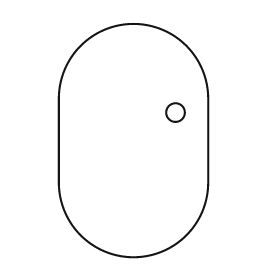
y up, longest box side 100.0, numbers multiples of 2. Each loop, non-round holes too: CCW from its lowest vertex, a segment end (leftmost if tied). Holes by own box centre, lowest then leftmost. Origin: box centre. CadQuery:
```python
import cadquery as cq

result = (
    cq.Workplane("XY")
    .moveTo(-32.0, -18.0)
    .threePointArc((0.0, -50.0), (32.0, -18.0))
    .lineTo(32.0, 18.0)
    .threePointArc((0.0, 50.0), (-32.0, 18.0))
    .close()
    .moveTo(18.0, 12.0)
    .circle(4.0)
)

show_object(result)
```